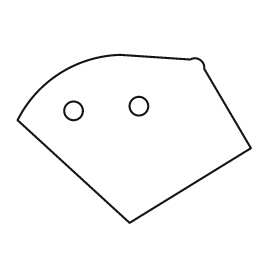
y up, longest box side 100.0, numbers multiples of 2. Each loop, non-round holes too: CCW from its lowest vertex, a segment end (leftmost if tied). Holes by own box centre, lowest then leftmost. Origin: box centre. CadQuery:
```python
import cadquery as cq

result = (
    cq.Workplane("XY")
    .moveTo(-2.0, -36.0)
    .lineTo(50.0, -4.0)
    .lineTo(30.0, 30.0)
    .threePointArc((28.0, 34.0), (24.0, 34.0))
    .lineTo(-6.0, 36.0)
    .threePointArc((-32.0, 28.0), (-50.0, 8.0))
    .close()
    .moveTo(-26.0, 12.0)
    .circle(4.0)
    .moveTo(2.0, 14.0)
    .circle(4.0)
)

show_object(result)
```